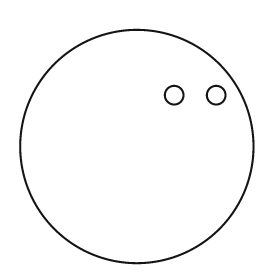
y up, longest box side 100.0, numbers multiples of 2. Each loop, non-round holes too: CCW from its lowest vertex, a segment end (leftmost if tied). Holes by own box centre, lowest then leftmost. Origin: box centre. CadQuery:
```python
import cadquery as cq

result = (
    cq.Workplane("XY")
    .moveTo(0.0, 0.0)
    .circle(50.0)
    .moveTo(16.0, 22.0)
    .circle(4.0)
    .moveTo(34.0, 22.0)
    .circle(4.0)
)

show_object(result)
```